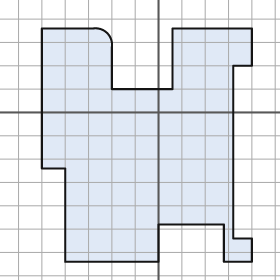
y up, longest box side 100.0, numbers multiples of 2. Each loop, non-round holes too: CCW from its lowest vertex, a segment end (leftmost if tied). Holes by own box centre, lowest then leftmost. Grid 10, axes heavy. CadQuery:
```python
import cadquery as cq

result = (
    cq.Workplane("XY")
    .moveTo(-40.0, -64.0)
    .lineTo(0.0, -64.0)
    .lineTo(0.0, -48.0)
    .lineTo(28.0, -48.0)
    .lineTo(28.0, -64.0)
    .lineTo(40.0, -64.0)
    .lineTo(40.0, -54.0)
    .lineTo(32.0, -54.0)
    .lineTo(32.0, 20.0)
    .lineTo(40.0, 20.0)
    .lineTo(40.0, 36.0)
    .lineTo(6.0, 36.0)
    .lineTo(6.0, 10.0)
    .lineTo(-20.0, 10.0)
    .lineTo(-20.0, 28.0)
    .threePointArc((-22.0, 34.0), (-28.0, 36.0))
    .lineTo(-50.0, 36.0)
    .lineTo(-50.0, -24.0)
    .lineTo(-40.0, -24.0)
    .close()
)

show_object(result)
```